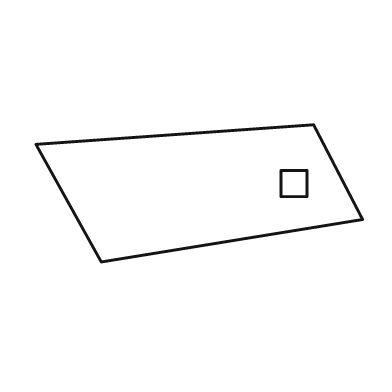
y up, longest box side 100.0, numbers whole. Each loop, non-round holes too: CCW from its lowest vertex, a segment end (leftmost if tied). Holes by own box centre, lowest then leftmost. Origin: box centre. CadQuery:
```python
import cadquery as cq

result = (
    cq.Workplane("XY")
    .moveTo(-30.0, -21.0)
    .lineTo(50.0, -8.0)
    .lineTo(35.0, 21.0)
    .lineTo(-50.0, 15.0)
    .close()
    .moveTo(25.0, -1.0)
    .lineTo(33.0, -1.0)
    .lineTo(33.0, 7.0)
    .lineTo(25.0, 7.0)
    .close()
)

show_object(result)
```